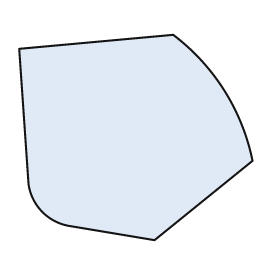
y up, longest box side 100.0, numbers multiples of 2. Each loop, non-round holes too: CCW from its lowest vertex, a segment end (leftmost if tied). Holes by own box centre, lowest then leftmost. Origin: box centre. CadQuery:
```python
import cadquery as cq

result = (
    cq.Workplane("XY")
    .moveTo(8.0, -44.0)
    .lineTo(50.0, -10.0)
    .threePointArc((38.0, 20.0), (16.0, 44.0))
    .lineTo(-50.0, 38.0)
    .lineTo(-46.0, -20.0)
    .threePointArc((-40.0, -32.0), (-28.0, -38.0))
    .close()
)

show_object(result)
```